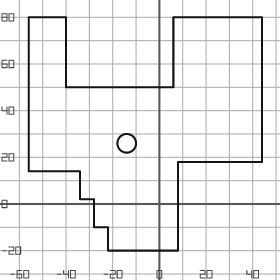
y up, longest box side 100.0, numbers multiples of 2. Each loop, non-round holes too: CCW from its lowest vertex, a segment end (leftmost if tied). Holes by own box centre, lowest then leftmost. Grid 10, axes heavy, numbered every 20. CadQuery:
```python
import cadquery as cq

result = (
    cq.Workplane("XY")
    .moveTo(-22.0, -20.0)
    .lineTo(8.0, -20.0)
    .lineTo(8.0, 18.0)
    .lineTo(44.0, 18.0)
    .lineTo(44.0, 80.0)
    .lineTo(6.0, 80.0)
    .lineTo(6.0, 50.0)
    .lineTo(-40.0, 50.0)
    .lineTo(-40.0, 80.0)
    .lineTo(-56.0, 80.0)
    .lineTo(-56.0, 14.0)
    .lineTo(-34.0, 14.0)
    .lineTo(-34.0, 2.0)
    .lineTo(-28.0, 2.0)
    .lineTo(-28.0, -10.0)
    .lineTo(-22.0, -10.0)
    .close()
    .moveTo(-14.0, 26.0)
    .circle(4.0)
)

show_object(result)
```